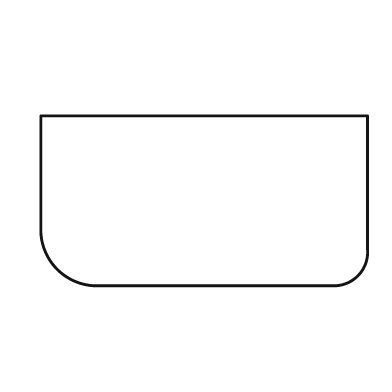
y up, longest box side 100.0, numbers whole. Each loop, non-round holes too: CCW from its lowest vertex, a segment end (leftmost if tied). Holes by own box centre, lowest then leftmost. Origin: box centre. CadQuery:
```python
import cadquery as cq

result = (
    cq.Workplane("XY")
    .moveTo(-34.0, -26.0)
    .lineTo(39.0, -26.0)
    .threePointArc((47.0, -23.0), (50.0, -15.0))
    .lineTo(50.0, 26.0)
    .lineTo(-50.0, 26.0)
    .lineTo(-50.0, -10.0)
    .threePointArc((-45.0, -21.0), (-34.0, -26.0))
    .close()
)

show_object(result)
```